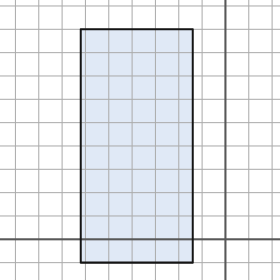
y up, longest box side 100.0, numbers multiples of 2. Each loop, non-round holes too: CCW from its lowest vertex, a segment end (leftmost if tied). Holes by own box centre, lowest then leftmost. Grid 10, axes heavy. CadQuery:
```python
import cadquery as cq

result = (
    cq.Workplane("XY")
    .moveTo(-62.0, -10.0)
    .lineTo(-14.0, -10.0)
    .lineTo(-14.0, 90.0)
    .lineTo(-62.0, 90.0)
    .close()
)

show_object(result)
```